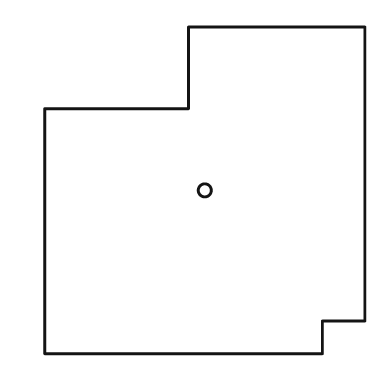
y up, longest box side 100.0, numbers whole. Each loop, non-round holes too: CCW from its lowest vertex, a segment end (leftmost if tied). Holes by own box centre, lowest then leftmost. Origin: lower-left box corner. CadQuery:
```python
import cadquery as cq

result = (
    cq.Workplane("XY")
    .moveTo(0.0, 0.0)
    .lineTo(85.0, 0.0)
    .lineTo(85.0, 10.0)
    .lineTo(98.0, 10.0)
    .lineTo(98.0, 100.0)
    .lineTo(44.0, 100.0)
    .lineTo(44.0, 75.0)
    .lineTo(0.0, 75.0)
    .close()
    .moveTo(49.0, 50.0)
    .circle(2.0)
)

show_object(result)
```